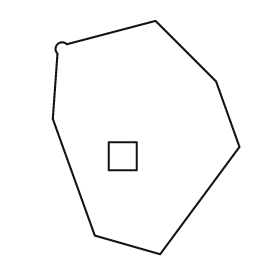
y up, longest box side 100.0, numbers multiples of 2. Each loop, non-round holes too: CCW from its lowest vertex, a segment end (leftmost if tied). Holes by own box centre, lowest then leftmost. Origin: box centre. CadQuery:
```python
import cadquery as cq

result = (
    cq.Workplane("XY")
    .moveTo(6.0, -50.0)
    .lineTo(40.0, -4.0)
    .lineTo(30.0, 24.0)
    .lineTo(4.0, 50.0)
    .lineTo(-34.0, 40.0)
    .threePointArc((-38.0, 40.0), (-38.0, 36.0))
    .lineTo(-40.0, 8.0)
    .lineTo(-22.0, -42.0)
    .close()
    .moveTo(-16.0, -14.0)
    .lineTo(-4.0, -14.0)
    .lineTo(-4.0, -2.0)
    .lineTo(-16.0, -2.0)
    .close()
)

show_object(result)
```